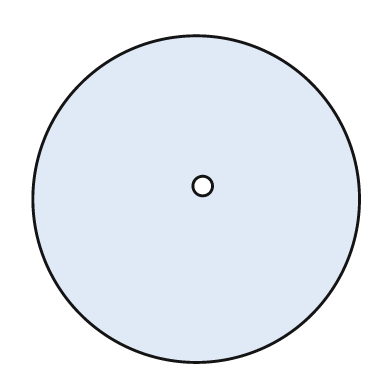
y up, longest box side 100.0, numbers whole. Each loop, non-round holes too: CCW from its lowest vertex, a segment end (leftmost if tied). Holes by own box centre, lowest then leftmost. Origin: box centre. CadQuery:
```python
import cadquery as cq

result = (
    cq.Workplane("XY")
    .moveTo(0.0, 0.0)
    .circle(50.0)
    .moveTo(2.0, 4.0)
    .circle(3.0)
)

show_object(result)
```